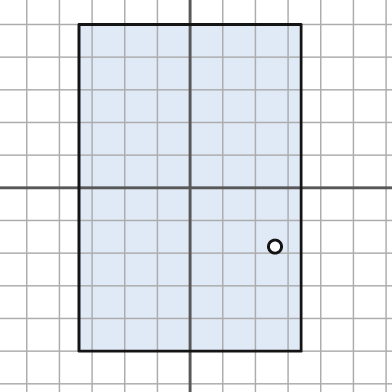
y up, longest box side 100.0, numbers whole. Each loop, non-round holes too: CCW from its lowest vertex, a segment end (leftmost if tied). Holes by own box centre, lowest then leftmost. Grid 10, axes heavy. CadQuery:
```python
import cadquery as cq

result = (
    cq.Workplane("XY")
    .moveTo(-34.0, -50.0)
    .lineTo(34.0, -50.0)
    .lineTo(34.0, 50.0)
    .lineTo(-34.0, 50.0)
    .close()
    .moveTo(26.0, -18.0)
    .circle(2.0)
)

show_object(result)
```